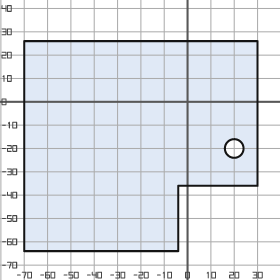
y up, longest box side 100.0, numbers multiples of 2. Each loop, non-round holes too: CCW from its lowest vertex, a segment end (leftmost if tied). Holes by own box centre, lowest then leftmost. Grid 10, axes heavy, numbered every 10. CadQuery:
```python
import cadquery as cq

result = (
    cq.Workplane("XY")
    .moveTo(-70.0, -64.0)
    .lineTo(-4.0, -64.0)
    .lineTo(-4.0, -36.0)
    .lineTo(30.0, -36.0)
    .lineTo(30.0, 26.0)
    .lineTo(-70.0, 26.0)
    .close()
    .moveTo(20.0, -20.0)
    .circle(4.0)
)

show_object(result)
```